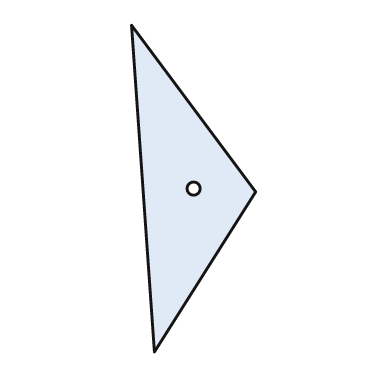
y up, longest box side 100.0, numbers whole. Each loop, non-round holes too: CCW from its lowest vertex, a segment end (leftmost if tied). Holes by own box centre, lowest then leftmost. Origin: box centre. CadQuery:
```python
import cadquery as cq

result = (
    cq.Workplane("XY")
    .moveTo(-12.0, -50.0)
    .lineTo(19.0, -1.0)
    .lineTo(-19.0, 50.0)
    .close()
    .moveTo(0.0, 0.0)
    .circle(2.0)
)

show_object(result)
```